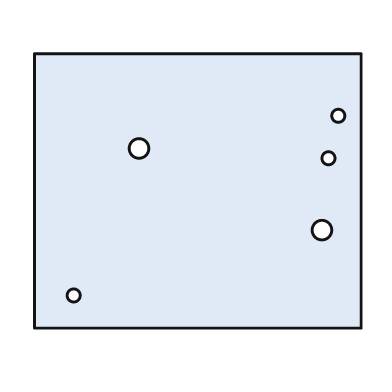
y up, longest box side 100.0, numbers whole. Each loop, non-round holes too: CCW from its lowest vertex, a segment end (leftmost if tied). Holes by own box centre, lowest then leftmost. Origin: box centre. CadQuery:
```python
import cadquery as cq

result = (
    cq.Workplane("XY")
    .moveTo(-50.0, -42.0)
    .lineTo(50.0, -42.0)
    .lineTo(50.0, 42.0)
    .lineTo(-50.0, 42.0)
    .close()
    .moveTo(-38.0, -32.0)
    .circle(2.0)
    .moveTo(38.0, -12.0)
    .circle(3.0)
    .moveTo(40.0, 10.0)
    .circle(2.0)
    .moveTo(-18.0, 13.0)
    .circle(3.0)
    .moveTo(43.0, 23.0)
    .circle(2.0)
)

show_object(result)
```